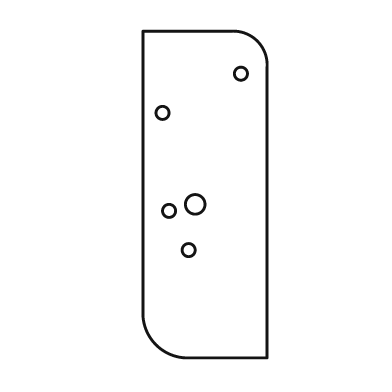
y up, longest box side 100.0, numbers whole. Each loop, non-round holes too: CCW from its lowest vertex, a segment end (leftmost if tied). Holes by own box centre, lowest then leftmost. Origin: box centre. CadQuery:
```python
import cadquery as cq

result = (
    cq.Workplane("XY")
    .moveTo(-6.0, -50.0)
    .lineTo(19.0, -50.0)
    .lineTo(19.0, 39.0)
    .threePointArc((16.0, 47.0), (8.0, 50.0))
    .lineTo(-19.0, 50.0)
    .lineTo(-19.0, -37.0)
    .threePointArc((-15.0, -46.0), (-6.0, -50.0))
    .close()
    .moveTo(-5.0, -17.0)
    .circle(2.0)
    .moveTo(-11.0, -5.0)
    .circle(2.0)
    .moveTo(-3.0, -3.0)
    .circle(3.0)
    .moveTo(-13.0, 25.0)
    .circle(2.0)
    .moveTo(11.0, 37.0)
    .circle(2.0)
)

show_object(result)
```